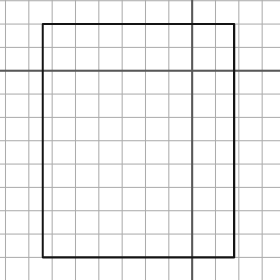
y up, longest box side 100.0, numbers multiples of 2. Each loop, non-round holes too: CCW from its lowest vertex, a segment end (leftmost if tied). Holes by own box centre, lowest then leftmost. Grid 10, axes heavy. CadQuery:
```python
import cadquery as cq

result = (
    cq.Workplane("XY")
    .moveTo(-64.0, -80.0)
    .lineTo(18.0, -80.0)
    .lineTo(18.0, 20.0)
    .lineTo(-64.0, 20.0)
    .close()
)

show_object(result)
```